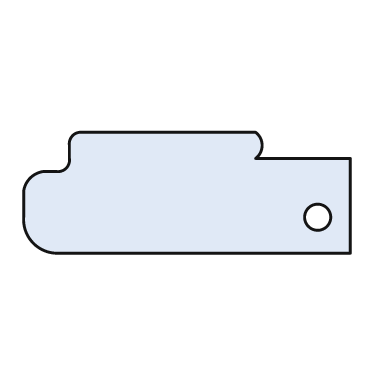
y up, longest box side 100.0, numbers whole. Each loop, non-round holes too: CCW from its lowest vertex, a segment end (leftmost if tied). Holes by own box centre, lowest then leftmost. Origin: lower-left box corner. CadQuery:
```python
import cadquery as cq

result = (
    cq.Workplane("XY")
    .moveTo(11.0, 0.0)
    .lineTo(100.0, 0.0)
    .lineTo(100.0, 29.0)
    .lineTo(71.0, 29.0)
    .threePointArc((73.0, 33.0), (71.0, 37.0))
    .lineTo(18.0, 37.0)
    .threePointArc((15.0, 36.0), (14.0, 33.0))
    .lineTo(14.0, 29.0)
    .threePointArc((13.0, 26.0), (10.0, 25.0))
    .lineTo(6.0, 25.0)
    .threePointArc((2.0, 23.0), (0.0, 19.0))
    .lineTo(0.0, 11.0)
    .threePointArc((3.0, 3.0), (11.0, 0.0))
    .close()
    .moveTo(90.0, 11.0)
    .circle(4.0)
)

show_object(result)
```